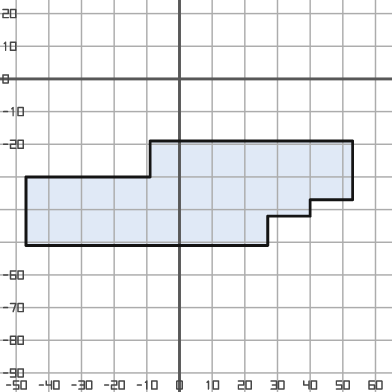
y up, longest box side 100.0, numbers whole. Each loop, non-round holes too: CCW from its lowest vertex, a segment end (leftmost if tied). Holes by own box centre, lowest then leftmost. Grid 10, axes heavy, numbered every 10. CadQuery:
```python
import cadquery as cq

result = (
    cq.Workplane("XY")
    .moveTo(-47.0, -51.0)
    .lineTo(27.0, -51.0)
    .lineTo(27.0, -42.0)
    .lineTo(40.0, -42.0)
    .lineTo(40.0, -37.0)
    .lineTo(53.0, -37.0)
    .lineTo(53.0, -19.0)
    .lineTo(-9.0, -19.0)
    .lineTo(-9.0, -30.0)
    .lineTo(-47.0, -30.0)
    .close()
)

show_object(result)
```